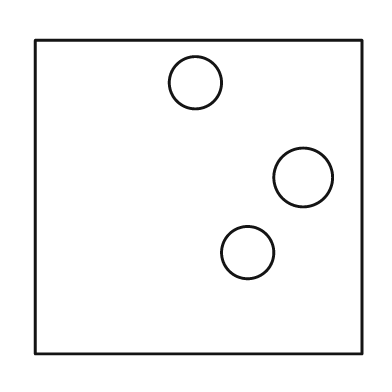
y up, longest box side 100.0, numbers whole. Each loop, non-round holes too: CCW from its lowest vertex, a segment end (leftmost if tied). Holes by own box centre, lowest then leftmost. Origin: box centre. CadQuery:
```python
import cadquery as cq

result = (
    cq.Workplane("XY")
    .moveTo(-50.0, -48.0)
    .lineTo(50.0, -48.0)
    .lineTo(50.0, 48.0)
    .lineTo(-50.0, 48.0)
    .close()
    .moveTo(15.0, -17.0)
    .circle(8.0)
    .moveTo(32.0, 6.0)
    .circle(9.0)
    .moveTo(-1.0, 35.0)
    .circle(8.0)
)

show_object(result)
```